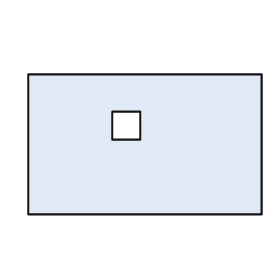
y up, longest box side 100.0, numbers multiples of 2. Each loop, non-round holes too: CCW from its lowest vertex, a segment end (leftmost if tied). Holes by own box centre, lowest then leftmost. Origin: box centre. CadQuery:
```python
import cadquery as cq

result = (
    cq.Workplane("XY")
    .moveTo(-50.0, -30.0)
    .lineTo(50.0, -30.0)
    .lineTo(50.0, 30.0)
    .lineTo(-50.0, 30.0)
    .close()
    .moveTo(-14.0, 2.0)
    .lineTo(-2.0, 2.0)
    .lineTo(-2.0, 14.0)
    .lineTo(-14.0, 14.0)
    .close()
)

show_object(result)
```